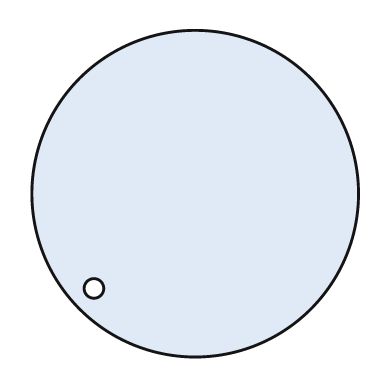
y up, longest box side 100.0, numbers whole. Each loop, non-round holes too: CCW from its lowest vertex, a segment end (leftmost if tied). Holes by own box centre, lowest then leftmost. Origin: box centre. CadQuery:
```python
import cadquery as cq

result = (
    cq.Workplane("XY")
    .moveTo(0.0, 0.0)
    .circle(50.0)
    .moveTo(-31.0, -29.0)
    .circle(3.0)
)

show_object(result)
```